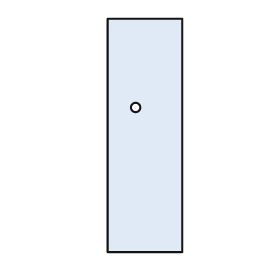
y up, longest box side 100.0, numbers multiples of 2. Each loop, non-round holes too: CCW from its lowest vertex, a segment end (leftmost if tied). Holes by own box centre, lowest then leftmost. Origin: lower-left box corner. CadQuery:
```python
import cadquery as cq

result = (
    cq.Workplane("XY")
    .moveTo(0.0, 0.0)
    .lineTo(32.0, 0.0)
    .lineTo(32.0, 100.0)
    .lineTo(0.0, 100.0)
    .close()
    .moveTo(12.0, 62.0)
    .circle(2.0)
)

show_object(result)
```